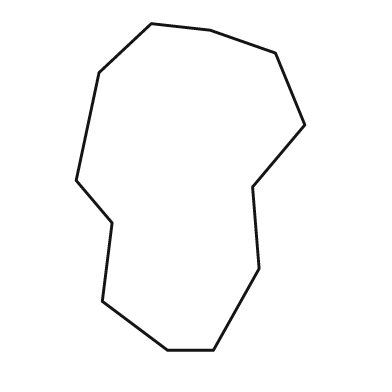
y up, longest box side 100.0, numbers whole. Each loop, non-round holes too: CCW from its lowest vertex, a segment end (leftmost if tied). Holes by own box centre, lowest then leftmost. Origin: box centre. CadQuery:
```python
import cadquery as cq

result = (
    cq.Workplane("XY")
    .moveTo(-7.0, -50.0)
    .lineTo(7.0, -50.0)
    .lineTo(21.0, -25.0)
    .lineTo(19.0, 0.0)
    .lineTo(35.0, 19.0)
    .lineTo(26.0, 41.0)
    .lineTo(6.0, 48.0)
    .lineTo(-12.0, 50.0)
    .lineTo(-28.0, 35.0)
    .lineTo(-35.0, 2.0)
    .lineTo(-24.0, -11.0)
    .lineTo(-27.0, -35.0)
    .close()
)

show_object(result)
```